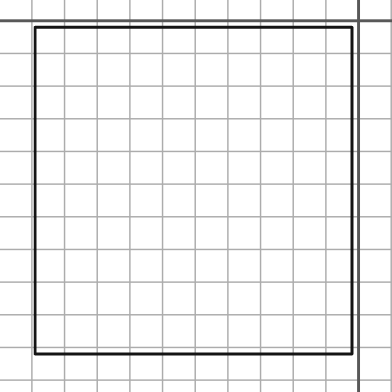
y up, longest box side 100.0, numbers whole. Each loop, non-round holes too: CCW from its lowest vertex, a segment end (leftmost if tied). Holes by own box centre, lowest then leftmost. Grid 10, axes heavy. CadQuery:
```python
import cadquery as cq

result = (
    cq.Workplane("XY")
    .moveTo(-99.0, -102.0)
    .lineTo(-2.0, -102.0)
    .lineTo(-2.0, -2.0)
    .lineTo(-99.0, -2.0)
    .close()
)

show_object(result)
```